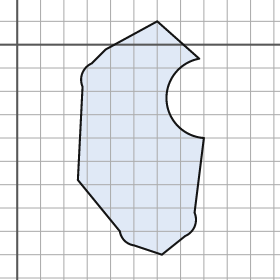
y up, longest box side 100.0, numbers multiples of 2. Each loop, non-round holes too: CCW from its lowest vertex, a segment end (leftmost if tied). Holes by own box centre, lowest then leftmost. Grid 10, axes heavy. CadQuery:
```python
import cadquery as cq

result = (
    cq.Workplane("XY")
    .moveTo(62.0, -90.0)
    .lineTo(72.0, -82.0)
    .threePointArc((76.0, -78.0), (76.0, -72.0))
    .lineTo(80.0, -40.0)
    .threePointArc((64.0, -24.0), (78.0, -6.0))
    .lineTo(60.0, 10.0)
    .lineTo(38.0, -2.0)
    .lineTo(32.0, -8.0)
    .threePointArc((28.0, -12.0), (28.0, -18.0))
    .lineTo(26.0, -58.0)
    .lineTo(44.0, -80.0)
    .threePointArc((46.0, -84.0), (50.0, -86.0))
    .close()
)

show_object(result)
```